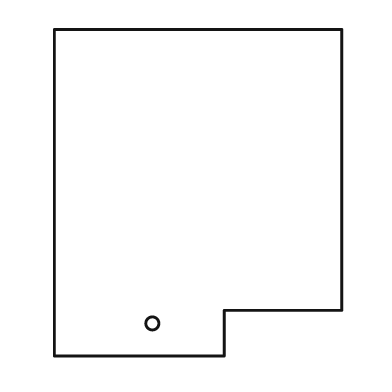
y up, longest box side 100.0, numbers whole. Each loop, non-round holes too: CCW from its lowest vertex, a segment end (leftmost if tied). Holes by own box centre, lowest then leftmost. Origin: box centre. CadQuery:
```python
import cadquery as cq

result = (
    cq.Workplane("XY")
    .moveTo(-44.0, -50.0)
    .lineTo(8.0, -50.0)
    .lineTo(8.0, -36.0)
    .lineTo(44.0, -36.0)
    .lineTo(44.0, 50.0)
    .lineTo(-44.0, 50.0)
    .close()
    .moveTo(-14.0, -40.0)
    .circle(2.0)
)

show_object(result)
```